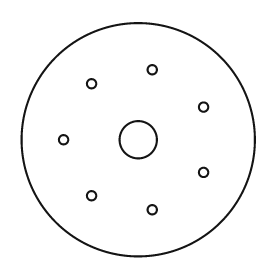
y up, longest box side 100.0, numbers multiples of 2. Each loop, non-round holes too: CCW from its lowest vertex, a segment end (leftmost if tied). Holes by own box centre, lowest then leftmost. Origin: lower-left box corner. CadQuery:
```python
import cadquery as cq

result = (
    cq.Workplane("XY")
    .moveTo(50.0, 50.0)
    .circle(50.0)
    .moveTo(56.0, 20.0)
    .circle(2.0)
    .moveTo(30.0, 26.0)
    .circle(2.0)
    .moveTo(78.0, 36.0)
    .circle(2.0)
    .moveTo(18.0, 50.0)
    .circle(2.0)
    .moveTo(50.0, 50.0)
    .circle(8.0)
    .moveTo(78.0, 64.0)
    .circle(2.0)
    .moveTo(30.0, 74.0)
    .circle(2.0)
    .moveTo(56.0, 80.0)
    .circle(2.0)
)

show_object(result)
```